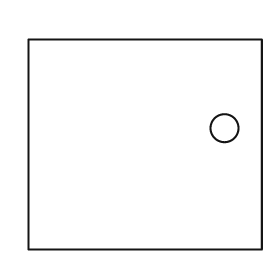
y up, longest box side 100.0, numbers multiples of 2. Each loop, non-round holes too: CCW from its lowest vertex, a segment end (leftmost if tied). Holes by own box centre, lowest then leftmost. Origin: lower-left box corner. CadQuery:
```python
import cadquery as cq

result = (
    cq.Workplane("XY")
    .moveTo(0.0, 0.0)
    .lineTo(100.0, 0.0)
    .lineTo(100.0, 90.0)
    .lineTo(0.0, 90.0)
    .close()
    .moveTo(84.0, 52.0)
    .circle(6.0)
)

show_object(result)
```